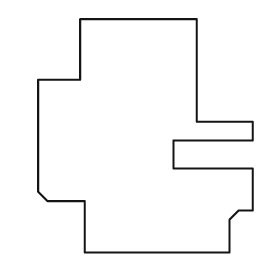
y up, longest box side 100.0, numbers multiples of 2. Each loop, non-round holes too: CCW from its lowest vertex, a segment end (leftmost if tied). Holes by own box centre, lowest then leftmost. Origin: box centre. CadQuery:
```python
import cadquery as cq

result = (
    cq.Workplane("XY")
    .moveTo(-26.0, -50.0)
    .lineTo(36.0, -50.0)
    .lineTo(36.0, -36.0)
    .lineTo(40.0, -32.0)
    .lineTo(46.0, -32.0)
    .lineTo(46.0, -14.0)
    .lineTo(12.0, -14.0)
    .lineTo(12.0, -2.0)
    .lineTo(46.0, -2.0)
    .lineTo(46.0, 6.0)
    .lineTo(22.0, 6.0)
    .lineTo(22.0, 50.0)
    .lineTo(-28.0, 50.0)
    .lineTo(-28.0, 24.0)
    .lineTo(-46.0, 24.0)
    .lineTo(-46.0, -24.0)
    .lineTo(-42.0, -28.0)
    .lineTo(-26.0, -28.0)
    .close()
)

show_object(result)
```